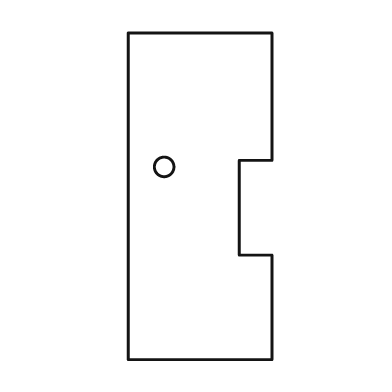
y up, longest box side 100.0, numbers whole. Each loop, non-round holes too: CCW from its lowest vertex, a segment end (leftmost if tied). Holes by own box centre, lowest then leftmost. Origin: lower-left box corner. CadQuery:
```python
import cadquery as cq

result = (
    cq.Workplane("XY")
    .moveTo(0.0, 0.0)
    .lineTo(44.0, 0.0)
    .lineTo(44.0, 32.0)
    .lineTo(34.0, 32.0)
    .lineTo(34.0, 61.0)
    .lineTo(44.0, 61.0)
    .lineTo(44.0, 100.0)
    .lineTo(0.0, 100.0)
    .close()
    .moveTo(11.0, 59.0)
    .circle(3.0)
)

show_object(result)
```